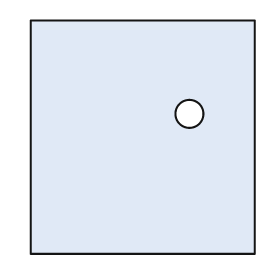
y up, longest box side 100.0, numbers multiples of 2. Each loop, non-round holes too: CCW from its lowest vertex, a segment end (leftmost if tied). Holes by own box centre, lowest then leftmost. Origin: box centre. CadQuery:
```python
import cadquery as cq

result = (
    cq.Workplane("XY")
    .moveTo(-48.0, -50.0)
    .lineTo(48.0, -50.0)
    .lineTo(48.0, 50.0)
    .lineTo(-48.0, 50.0)
    .close()
    .moveTo(20.0, 10.0)
    .circle(6.0)
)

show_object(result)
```